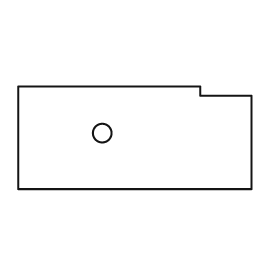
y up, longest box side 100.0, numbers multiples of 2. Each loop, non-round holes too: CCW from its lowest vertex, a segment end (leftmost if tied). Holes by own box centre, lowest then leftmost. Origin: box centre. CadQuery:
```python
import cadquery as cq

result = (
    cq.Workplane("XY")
    .moveTo(-50.0, -22.0)
    .lineTo(50.0, -22.0)
    .lineTo(50.0, 18.0)
    .lineTo(28.0, 18.0)
    .lineTo(28.0, 22.0)
    .lineTo(-50.0, 22.0)
    .close()
    .moveTo(-14.0, 2.0)
    .circle(4.0)
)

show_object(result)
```